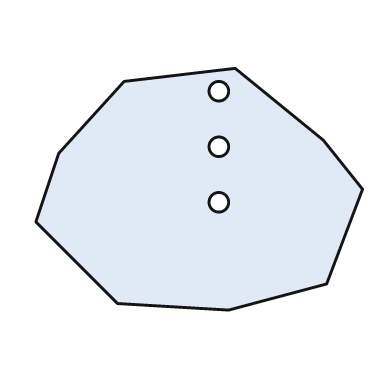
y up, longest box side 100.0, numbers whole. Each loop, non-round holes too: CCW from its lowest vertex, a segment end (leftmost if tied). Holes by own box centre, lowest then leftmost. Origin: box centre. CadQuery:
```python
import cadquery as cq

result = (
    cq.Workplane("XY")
    .moveTo(9.0, -37.0)
    .lineTo(39.0, -29.0)
    .lineTo(50.0, 0.0)
    .lineTo(38.0, 15.0)
    .lineTo(11.0, 37.0)
    .lineTo(-23.0, 33.0)
    .lineTo(-43.0, 11.0)
    .lineTo(-50.0, -10.0)
    .lineTo(-25.0, -35.0)
    .close()
    .moveTo(6.0, -4.0)
    .circle(3.0)
    .moveTo(6.0, 13.0)
    .circle(3.0)
    .moveTo(6.0, 30.0)
    .circle(3.0)
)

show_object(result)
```